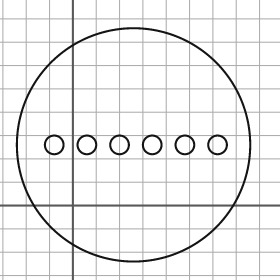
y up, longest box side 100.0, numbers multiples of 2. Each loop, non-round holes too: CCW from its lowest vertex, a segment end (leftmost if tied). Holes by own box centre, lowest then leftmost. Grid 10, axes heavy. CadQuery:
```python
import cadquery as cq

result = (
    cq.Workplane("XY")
    .moveTo(26.0, 26.0)
    .circle(50.0)
    .moveTo(-8.0, 26.0)
    .circle(4.0)
    .moveTo(6.0, 26.0)
    .circle(4.0)
    .moveTo(20.0, 26.0)
    .circle(4.0)
    .moveTo(34.0, 26.0)
    .circle(4.0)
    .moveTo(48.0, 26.0)
    .circle(4.0)
    .moveTo(62.0, 26.0)
    .circle(4.0)
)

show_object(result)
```